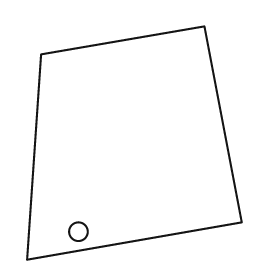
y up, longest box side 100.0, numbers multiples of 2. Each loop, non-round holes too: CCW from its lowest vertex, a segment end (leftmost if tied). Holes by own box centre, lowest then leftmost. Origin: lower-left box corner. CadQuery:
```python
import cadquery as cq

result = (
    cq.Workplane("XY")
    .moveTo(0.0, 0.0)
    .lineTo(92.0, 16.0)
    .lineTo(76.0, 100.0)
    .lineTo(6.0, 88.0)
    .close()
    .moveTo(22.0, 12.0)
    .circle(4.0)
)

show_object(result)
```